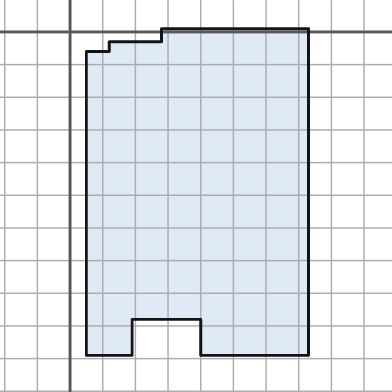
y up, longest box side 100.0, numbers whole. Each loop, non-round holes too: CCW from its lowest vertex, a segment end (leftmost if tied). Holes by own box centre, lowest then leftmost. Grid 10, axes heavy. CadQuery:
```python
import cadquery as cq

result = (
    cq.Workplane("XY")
    .moveTo(5.0, -99.0)
    .lineTo(19.0, -99.0)
    .lineTo(19.0, -88.0)
    .lineTo(40.0, -88.0)
    .lineTo(40.0, -99.0)
    .lineTo(73.0, -99.0)
    .lineTo(73.0, 1.0)
    .lineTo(28.0, 1.0)
    .lineTo(28.0, -3.0)
    .lineTo(12.0, -3.0)
    .lineTo(12.0, -6.0)
    .lineTo(5.0, -6.0)
    .close()
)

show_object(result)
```